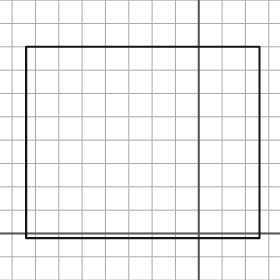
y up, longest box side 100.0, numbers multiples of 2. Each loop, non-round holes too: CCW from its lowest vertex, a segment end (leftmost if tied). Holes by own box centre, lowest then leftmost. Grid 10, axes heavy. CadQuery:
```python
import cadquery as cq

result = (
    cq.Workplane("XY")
    .moveTo(-74.0, -2.0)
    .lineTo(26.0, -2.0)
    .lineTo(26.0, 80.0)
    .lineTo(-74.0, 80.0)
    .close()
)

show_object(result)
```